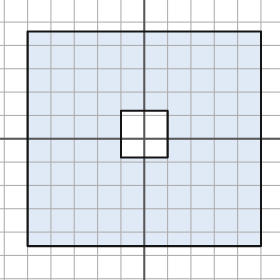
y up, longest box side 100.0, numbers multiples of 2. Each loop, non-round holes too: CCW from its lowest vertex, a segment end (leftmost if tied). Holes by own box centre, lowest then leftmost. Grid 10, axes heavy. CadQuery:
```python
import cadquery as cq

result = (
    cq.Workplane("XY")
    .moveTo(-50.0, -46.0)
    .lineTo(50.0, -46.0)
    .lineTo(50.0, 46.0)
    .lineTo(-50.0, 46.0)
    .close()
    .moveTo(-10.0, -8.0)
    .lineTo(10.0, -8.0)
    .lineTo(10.0, 12.0)
    .lineTo(-10.0, 12.0)
    .close()
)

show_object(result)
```